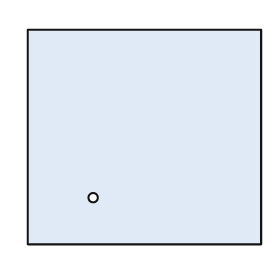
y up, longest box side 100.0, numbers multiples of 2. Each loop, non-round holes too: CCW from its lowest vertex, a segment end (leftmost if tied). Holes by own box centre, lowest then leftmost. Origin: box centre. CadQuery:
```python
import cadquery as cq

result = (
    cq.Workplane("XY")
    .moveTo(-50.0, -46.0)
    .lineTo(50.0, -46.0)
    .lineTo(50.0, 46.0)
    .lineTo(-50.0, 46.0)
    .close()
    .moveTo(-22.0, -26.0)
    .circle(2.0)
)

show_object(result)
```